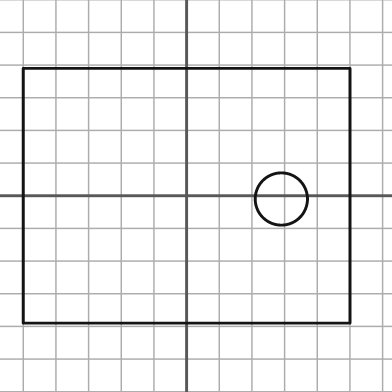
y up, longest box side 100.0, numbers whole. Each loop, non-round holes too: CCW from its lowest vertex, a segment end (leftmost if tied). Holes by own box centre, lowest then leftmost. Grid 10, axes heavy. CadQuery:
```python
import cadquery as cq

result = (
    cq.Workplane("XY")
    .moveTo(-50.0, -39.0)
    .lineTo(50.0, -39.0)
    .lineTo(50.0, 39.0)
    .lineTo(-50.0, 39.0)
    .close()
    .moveTo(29.0, -1.0)
    .circle(8.0)
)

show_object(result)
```